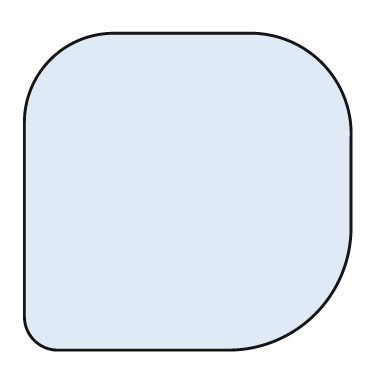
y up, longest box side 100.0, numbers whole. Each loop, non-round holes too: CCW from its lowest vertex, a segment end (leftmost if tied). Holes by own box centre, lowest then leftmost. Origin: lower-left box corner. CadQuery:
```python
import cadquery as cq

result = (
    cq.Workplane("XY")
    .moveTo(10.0, 0.0)
    .lineTo(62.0, 0.0)
    .threePointArc((89.0, 11.0), (100.0, 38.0))
    .lineTo(100.0, 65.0)
    .threePointArc((91.0, 88.0), (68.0, 97.0))
    .lineTo(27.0, 97.0)
    .threePointArc((8.0, 89.0), (0.0, 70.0))
    .lineTo(0.0, 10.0)
    .threePointArc((3.0, 3.0), (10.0, 0.0))
    .close()
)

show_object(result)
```